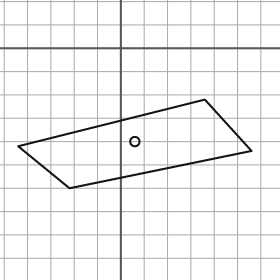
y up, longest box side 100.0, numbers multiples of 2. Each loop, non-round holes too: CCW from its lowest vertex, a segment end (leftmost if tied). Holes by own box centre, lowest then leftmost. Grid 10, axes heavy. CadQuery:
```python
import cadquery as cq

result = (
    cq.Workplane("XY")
    .moveTo(-22.0, -60.0)
    .lineTo(56.0, -44.0)
    .lineTo(36.0, -22.0)
    .lineTo(-44.0, -42.0)
    .close()
    .moveTo(6.0, -40.0)
    .circle(2.0)
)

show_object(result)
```